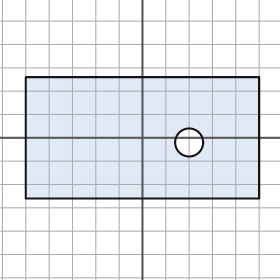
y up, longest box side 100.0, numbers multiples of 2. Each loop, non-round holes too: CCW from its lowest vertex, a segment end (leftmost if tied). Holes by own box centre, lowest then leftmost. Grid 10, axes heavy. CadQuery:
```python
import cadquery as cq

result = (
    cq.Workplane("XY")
    .moveTo(-50.0, -26.0)
    .lineTo(50.0, -26.0)
    .lineTo(50.0, 26.0)
    .lineTo(-50.0, 26.0)
    .close()
    .moveTo(20.0, -2.0)
    .circle(6.0)
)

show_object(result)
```